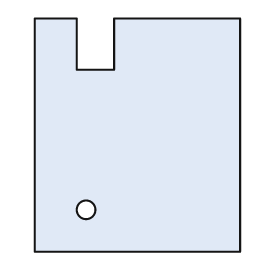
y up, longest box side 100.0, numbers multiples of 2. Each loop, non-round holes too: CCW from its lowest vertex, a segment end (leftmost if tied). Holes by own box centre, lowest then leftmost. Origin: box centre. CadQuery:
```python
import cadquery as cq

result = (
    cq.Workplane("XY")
    .moveTo(-44.0, -50.0)
    .lineTo(44.0, -50.0)
    .lineTo(44.0, 50.0)
    .lineTo(-10.0, 50.0)
    .lineTo(-10.0, 28.0)
    .lineTo(-26.0, 28.0)
    .lineTo(-26.0, 50.0)
    .lineTo(-44.0, 50.0)
    .close()
    .moveTo(-22.0, -32.0)
    .circle(4.0)
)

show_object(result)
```